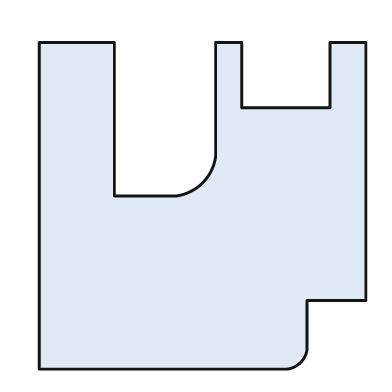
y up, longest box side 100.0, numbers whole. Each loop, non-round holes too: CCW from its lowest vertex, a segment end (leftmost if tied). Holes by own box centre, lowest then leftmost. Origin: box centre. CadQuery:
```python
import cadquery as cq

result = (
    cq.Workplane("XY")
    .moveTo(-50.0, -50.0)
    .lineTo(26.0, -50.0)
    .threePointArc((30.0, -48.0), (32.0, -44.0))
    .lineTo(32.0, -29.0)
    .lineTo(50.0, -29.0)
    .lineTo(50.0, 50.0)
    .lineTo(39.0, 50.0)
    .lineTo(39.0, 30.0)
    .lineTo(12.0, 30.0)
    .lineTo(12.0, 50.0)
    .lineTo(4.0, 50.0)
    .lineTo(4.0, 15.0)
    .threePointArc((0.0, 7.0), (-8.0, 3.0))
    .lineTo(-27.0, 3.0)
    .lineTo(-27.0, 50.0)
    .lineTo(-50.0, 50.0)
    .close()
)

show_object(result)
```